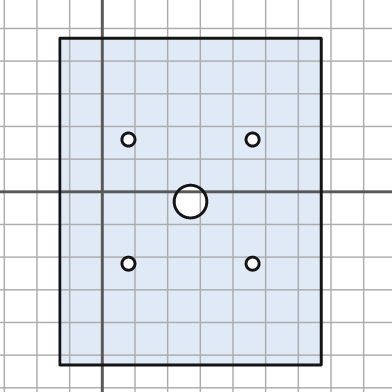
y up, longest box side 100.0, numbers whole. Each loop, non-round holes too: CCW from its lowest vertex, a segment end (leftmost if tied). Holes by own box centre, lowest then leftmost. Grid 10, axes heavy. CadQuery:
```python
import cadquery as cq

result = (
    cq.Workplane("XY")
    .moveTo(-13.0, -53.0)
    .lineTo(67.0, -53.0)
    .lineTo(67.0, 47.0)
    .lineTo(-13.0, 47.0)
    .close()
    .moveTo(8.0, -22.0)
    .circle(2.0)
    .moveTo(46.0, -22.0)
    .circle(2.0)
    .moveTo(27.0, -3.0)
    .circle(5.0)
    .moveTo(8.0, 16.0)
    .circle(2.0)
    .moveTo(46.0, 16.0)
    .circle(2.0)
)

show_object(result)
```